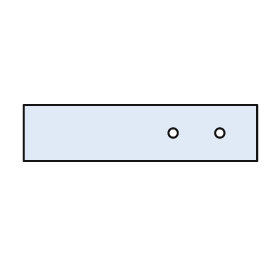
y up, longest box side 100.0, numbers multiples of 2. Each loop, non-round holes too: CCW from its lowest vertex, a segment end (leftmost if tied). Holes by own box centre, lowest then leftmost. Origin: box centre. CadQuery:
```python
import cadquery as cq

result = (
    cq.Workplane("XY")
    .moveTo(-50.0, -12.0)
    .lineTo(50.0, -12.0)
    .lineTo(50.0, 12.0)
    .lineTo(-50.0, 12.0)
    .close()
    .moveTo(14.0, 0.0)
    .circle(2.0)
    .moveTo(34.0, 0.0)
    .circle(2.0)
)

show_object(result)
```